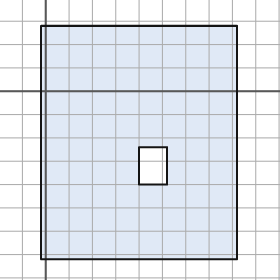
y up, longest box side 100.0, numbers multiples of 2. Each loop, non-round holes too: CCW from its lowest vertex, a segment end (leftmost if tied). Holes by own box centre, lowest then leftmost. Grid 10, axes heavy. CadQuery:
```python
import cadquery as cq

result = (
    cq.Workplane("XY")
    .moveTo(-2.0, -72.0)
    .lineTo(82.0, -72.0)
    .lineTo(82.0, 28.0)
    .lineTo(-2.0, 28.0)
    .close()
    .moveTo(40.0, -40.0)
    .lineTo(52.0, -40.0)
    .lineTo(52.0, -24.0)
    .lineTo(40.0, -24.0)
    .close()
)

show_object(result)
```